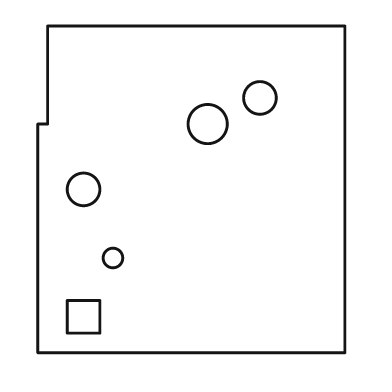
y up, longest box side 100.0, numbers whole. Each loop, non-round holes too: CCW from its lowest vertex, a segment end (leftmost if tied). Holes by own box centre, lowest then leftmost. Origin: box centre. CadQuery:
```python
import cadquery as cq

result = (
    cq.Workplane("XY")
    .moveTo(-47.0, -50.0)
    .lineTo(47.0, -50.0)
    .lineTo(47.0, 50.0)
    .lineTo(-44.0, 50.0)
    .lineTo(-44.0, 20.0)
    .lineTo(-47.0, 20.0)
    .close()
    .moveTo(-38.0, -44.0)
    .lineTo(-28.0, -44.0)
    .lineTo(-28.0, -34.0)
    .lineTo(-38.0, -34.0)
    .close()
    .moveTo(-24.0, -21.0)
    .circle(3.0)
    .moveTo(-33.0, 0.0)
    .circle(5.0)
    .moveTo(5.0, 20.0)
    .circle(6.0)
    .moveTo(21.0, 28.0)
    .circle(5.0)
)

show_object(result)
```